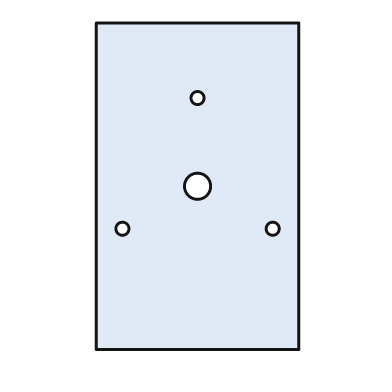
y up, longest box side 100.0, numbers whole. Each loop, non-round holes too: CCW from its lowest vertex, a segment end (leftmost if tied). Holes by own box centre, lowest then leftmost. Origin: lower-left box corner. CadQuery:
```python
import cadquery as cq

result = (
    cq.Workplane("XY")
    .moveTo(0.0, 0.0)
    .lineTo(62.0, 0.0)
    .lineTo(62.0, 100.0)
    .lineTo(0.0, 100.0)
    .close()
    .moveTo(8.0, 37.0)
    .circle(2.0)
    .moveTo(54.0, 37.0)
    .circle(2.0)
    .moveTo(31.0, 50.0)
    .circle(4.0)
    .moveTo(31.0, 77.0)
    .circle(2.0)
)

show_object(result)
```